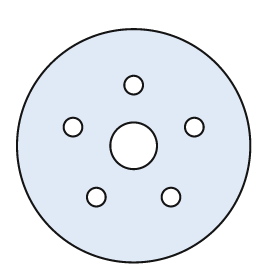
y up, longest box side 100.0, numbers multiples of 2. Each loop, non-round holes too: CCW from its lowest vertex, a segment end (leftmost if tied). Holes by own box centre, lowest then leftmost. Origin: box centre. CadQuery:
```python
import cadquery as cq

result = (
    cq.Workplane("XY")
    .moveTo(0.0, 0.0)
    .circle(50.0)
    .moveTo(-16.0, -22.0)
    .circle(4.0)
    .moveTo(16.0, -22.0)
    .circle(4.0)
    .moveTo(0.0, 0.0)
    .circle(10.0)
    .moveTo(-26.0, 8.0)
    .circle(4.0)
    .moveTo(26.0, 8.0)
    .circle(4.0)
    .moveTo(0.0, 26.0)
    .circle(4.0)
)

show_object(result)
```